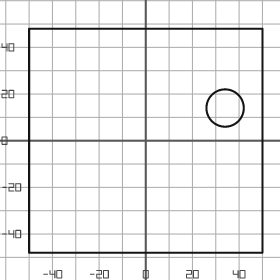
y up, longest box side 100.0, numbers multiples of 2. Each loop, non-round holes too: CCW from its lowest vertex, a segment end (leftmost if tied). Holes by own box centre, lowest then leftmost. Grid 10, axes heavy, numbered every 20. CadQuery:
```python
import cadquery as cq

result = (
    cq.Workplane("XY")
    .moveTo(-50.0, -48.0)
    .lineTo(50.0, -48.0)
    .lineTo(50.0, 48.0)
    .lineTo(-50.0, 48.0)
    .close()
    .moveTo(34.0, 14.0)
    .circle(8.0)
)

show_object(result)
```